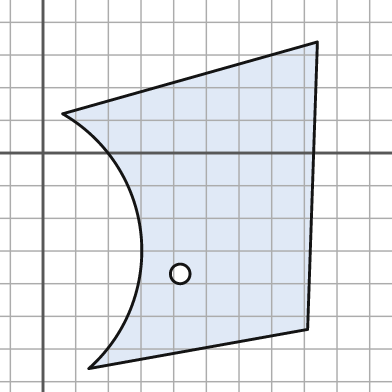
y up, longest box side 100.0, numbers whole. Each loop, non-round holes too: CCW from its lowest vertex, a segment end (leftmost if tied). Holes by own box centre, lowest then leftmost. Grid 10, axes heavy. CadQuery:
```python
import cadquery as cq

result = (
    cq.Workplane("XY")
    .moveTo(14.0, -66.0)
    .lineTo(81.0, -54.0)
    .lineTo(84.0, 34.0)
    .lineTo(6.0, 12.0)
    .threePointArc((30.0, -25.0), (14.0, -66.0))
    .close()
    .moveTo(42.0, -37.0)
    .circle(3.0)
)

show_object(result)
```